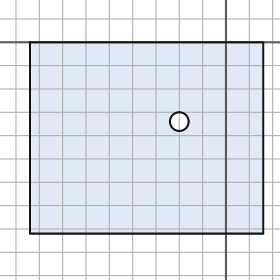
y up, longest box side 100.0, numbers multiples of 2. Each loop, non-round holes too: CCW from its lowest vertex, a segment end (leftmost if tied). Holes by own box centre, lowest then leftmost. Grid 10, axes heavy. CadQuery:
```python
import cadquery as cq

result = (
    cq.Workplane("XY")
    .moveTo(-84.0, -82.0)
    .lineTo(16.0, -82.0)
    .lineTo(16.0, 0.0)
    .lineTo(-84.0, 0.0)
    .close()
    .moveTo(-20.0, -34.0)
    .circle(4.0)
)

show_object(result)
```